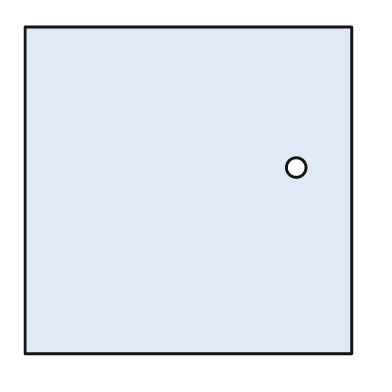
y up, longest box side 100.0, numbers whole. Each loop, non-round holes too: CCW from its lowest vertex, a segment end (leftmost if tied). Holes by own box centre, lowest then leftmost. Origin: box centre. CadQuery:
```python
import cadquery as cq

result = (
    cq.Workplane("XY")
    .moveTo(-50.0, -50.0)
    .lineTo(50.0, -50.0)
    .lineTo(50.0, 50.0)
    .lineTo(-50.0, 50.0)
    .close()
    .moveTo(33.0, 7.0)
    .circle(3.0)
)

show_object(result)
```